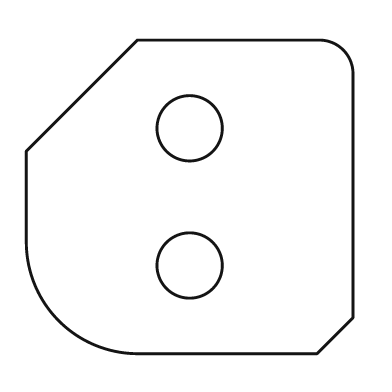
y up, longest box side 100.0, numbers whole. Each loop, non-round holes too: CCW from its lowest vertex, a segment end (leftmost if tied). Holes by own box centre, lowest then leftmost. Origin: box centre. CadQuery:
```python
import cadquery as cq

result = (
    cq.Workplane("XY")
    .moveTo(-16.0, -48.0)
    .lineTo(39.0, -48.0)
    .lineTo(50.0, -37.0)
    .lineTo(50.0, 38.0)
    .threePointArc((47.0, 45.0), (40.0, 48.0))
    .lineTo(-16.0, 48.0)
    .lineTo(-50.0, 14.0)
    .lineTo(-50.0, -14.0)
    .threePointArc((-40.0, -38.0), (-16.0, -48.0))
    .close()
    .moveTo(0.0, -21.0)
    .circle(10.0)
    .moveTo(0.0, 21.0)
    .circle(10.0)
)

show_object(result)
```